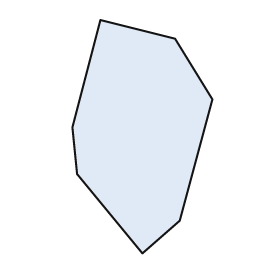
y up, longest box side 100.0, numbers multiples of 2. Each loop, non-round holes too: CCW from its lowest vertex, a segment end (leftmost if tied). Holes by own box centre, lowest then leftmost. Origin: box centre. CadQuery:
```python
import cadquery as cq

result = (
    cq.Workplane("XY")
    .moveTo(0.0, -50.0)
    .lineTo(16.0, -36.0)
    .lineTo(30.0, 16.0)
    .lineTo(14.0, 42.0)
    .lineTo(-18.0, 50.0)
    .lineTo(-30.0, 4.0)
    .lineTo(-28.0, -16.0)
    .close()
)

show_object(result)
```